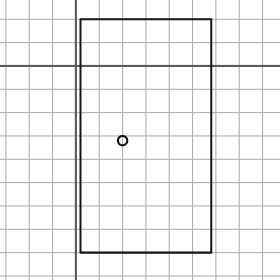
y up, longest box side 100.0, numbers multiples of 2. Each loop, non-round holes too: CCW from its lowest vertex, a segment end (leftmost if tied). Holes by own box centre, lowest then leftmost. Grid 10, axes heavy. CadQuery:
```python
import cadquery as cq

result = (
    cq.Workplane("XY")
    .moveTo(2.0, -80.0)
    .lineTo(58.0, -80.0)
    .lineTo(58.0, 20.0)
    .lineTo(2.0, 20.0)
    .close()
    .moveTo(20.0, -32.0)
    .circle(2.0)
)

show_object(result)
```